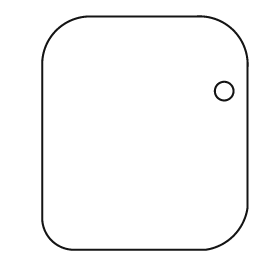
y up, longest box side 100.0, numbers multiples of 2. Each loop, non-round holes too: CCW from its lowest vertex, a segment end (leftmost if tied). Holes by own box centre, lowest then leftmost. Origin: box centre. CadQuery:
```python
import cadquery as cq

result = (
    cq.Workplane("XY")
    .moveTo(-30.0, -50.0)
    .lineTo(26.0, -50.0)
    .threePointArc((38.0, -44.0), (44.0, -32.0))
    .lineTo(44.0, 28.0)
    .threePointArc((38.0, 44.0), (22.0, 50.0))
    .lineTo(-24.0, 50.0)
    .threePointArc((-38.0, 44.0), (-44.0, 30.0))
    .lineTo(-44.0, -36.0)
    .threePointArc((-40.0, -46.0), (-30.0, -50.0))
    .close()
    .moveTo(34.0, 18.0)
    .circle(4.0)
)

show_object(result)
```